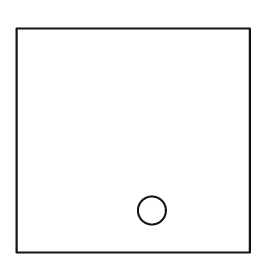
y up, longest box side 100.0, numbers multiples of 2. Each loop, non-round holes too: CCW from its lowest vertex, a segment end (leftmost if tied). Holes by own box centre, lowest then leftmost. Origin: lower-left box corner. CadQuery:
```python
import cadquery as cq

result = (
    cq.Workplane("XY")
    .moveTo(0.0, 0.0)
    .lineTo(100.0, 0.0)
    .lineTo(100.0, 96.0)
    .lineTo(0.0, 96.0)
    .close()
    .moveTo(58.0, 18.0)
    .circle(6.0)
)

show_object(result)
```